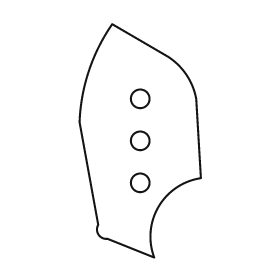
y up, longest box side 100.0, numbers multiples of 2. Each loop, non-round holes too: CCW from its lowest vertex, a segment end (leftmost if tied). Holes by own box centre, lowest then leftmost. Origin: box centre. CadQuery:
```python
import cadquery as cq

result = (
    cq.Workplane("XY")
    .moveTo(6.0, -50.0)
    .threePointArc((8.0, -28.0), (26.0, -16.0))
    .lineTo(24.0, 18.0)
    .threePointArc((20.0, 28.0), (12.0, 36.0))
    .lineTo(-12.0, 50.0)
    .threePointArc((-22.0, 30.0), (-26.0, 8.0))
    .lineTo(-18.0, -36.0)
    .threePointArc((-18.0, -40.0), (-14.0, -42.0))
    .close()
    .moveTo(0.0, -18.0)
    .circle(4.0)
    .moveTo(0.0, 0.0)
    .circle(4.0)
    .moveTo(0.0, 18.0)
    .circle(4.0)
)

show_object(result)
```